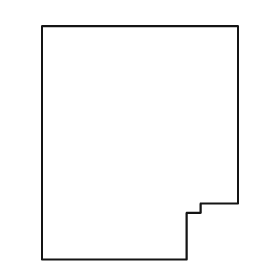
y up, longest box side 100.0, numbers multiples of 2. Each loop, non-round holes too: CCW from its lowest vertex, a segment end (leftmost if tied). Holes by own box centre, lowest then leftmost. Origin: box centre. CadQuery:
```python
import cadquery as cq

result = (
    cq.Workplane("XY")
    .moveTo(-42.0, -50.0)
    .lineTo(20.0, -50.0)
    .lineTo(20.0, -30.0)
    .lineTo(26.0, -30.0)
    .lineTo(26.0, -26.0)
    .lineTo(42.0, -26.0)
    .lineTo(42.0, 50.0)
    .lineTo(-42.0, 50.0)
    .close()
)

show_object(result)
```